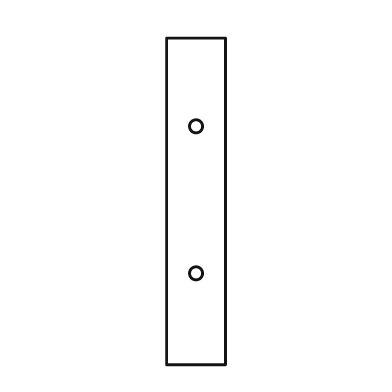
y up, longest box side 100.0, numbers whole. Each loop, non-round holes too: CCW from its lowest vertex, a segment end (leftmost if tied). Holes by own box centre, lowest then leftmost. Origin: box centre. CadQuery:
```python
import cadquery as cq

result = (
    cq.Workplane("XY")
    .moveTo(-9.0, -50.0)
    .lineTo(9.0, -50.0)
    .lineTo(9.0, 50.0)
    .lineTo(-9.0, 50.0)
    .close()
    .moveTo(0.0, -22.0)
    .circle(2.0)
    .moveTo(0.0, 23.0)
    .circle(2.0)
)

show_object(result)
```